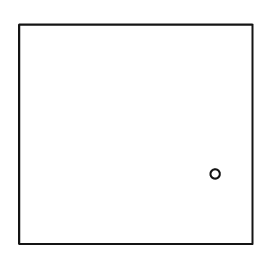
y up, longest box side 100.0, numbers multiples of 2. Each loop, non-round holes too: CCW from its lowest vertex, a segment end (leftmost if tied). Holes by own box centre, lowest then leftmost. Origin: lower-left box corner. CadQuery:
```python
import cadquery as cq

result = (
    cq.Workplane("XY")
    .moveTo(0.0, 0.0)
    .lineTo(100.0, 0.0)
    .lineTo(100.0, 94.0)
    .lineTo(0.0, 94.0)
    .close()
    .moveTo(84.0, 30.0)
    .circle(2.0)
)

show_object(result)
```